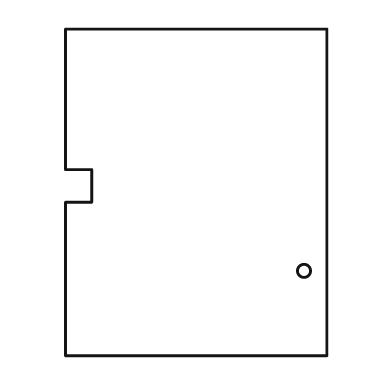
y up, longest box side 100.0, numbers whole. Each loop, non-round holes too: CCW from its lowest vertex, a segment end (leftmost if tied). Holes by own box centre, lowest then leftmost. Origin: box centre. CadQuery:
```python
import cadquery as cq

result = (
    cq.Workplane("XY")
    .moveTo(-40.0, -50.0)
    .lineTo(40.0, -50.0)
    .lineTo(40.0, 50.0)
    .lineTo(-40.0, 50.0)
    .lineTo(-40.0, 7.0)
    .lineTo(-32.0, 7.0)
    .lineTo(-32.0, -3.0)
    .lineTo(-40.0, -3.0)
    .close()
    .moveTo(33.0, -24.0)
    .circle(2.0)
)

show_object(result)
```